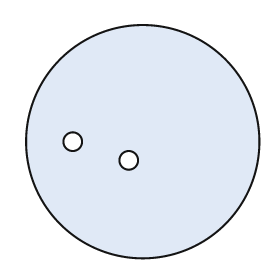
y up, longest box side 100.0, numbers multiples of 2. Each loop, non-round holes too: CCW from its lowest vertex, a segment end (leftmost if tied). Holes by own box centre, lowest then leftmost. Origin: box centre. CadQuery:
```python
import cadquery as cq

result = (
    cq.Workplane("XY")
    .moveTo(0.0, 0.0)
    .circle(50.0)
    .moveTo(-6.0, -8.0)
    .circle(4.0)
    .moveTo(-30.0, 0.0)
    .circle(4.0)
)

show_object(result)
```